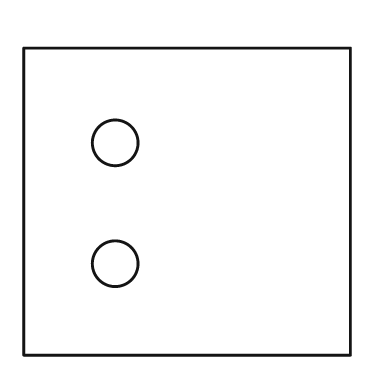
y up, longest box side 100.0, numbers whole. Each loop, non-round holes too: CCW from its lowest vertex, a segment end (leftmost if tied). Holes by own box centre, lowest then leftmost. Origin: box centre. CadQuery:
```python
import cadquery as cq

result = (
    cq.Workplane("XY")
    .moveTo(-50.0, -47.0)
    .lineTo(50.0, -47.0)
    .lineTo(50.0, 47.0)
    .lineTo(-50.0, 47.0)
    .close()
    .moveTo(-22.0, -19.0)
    .circle(7.0)
    .moveTo(-22.0, 18.0)
    .circle(7.0)
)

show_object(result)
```